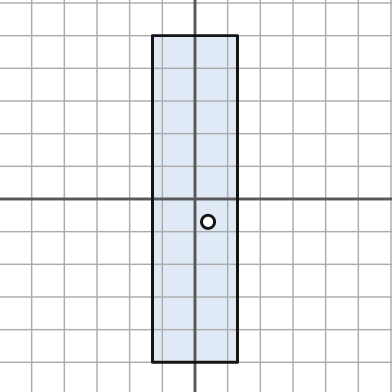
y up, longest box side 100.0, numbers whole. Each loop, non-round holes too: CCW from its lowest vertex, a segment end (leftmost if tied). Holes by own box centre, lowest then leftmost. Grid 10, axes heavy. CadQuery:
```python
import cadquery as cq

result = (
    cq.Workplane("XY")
    .moveTo(-13.0, -50.0)
    .lineTo(13.0, -50.0)
    .lineTo(13.0, 50.0)
    .lineTo(-13.0, 50.0)
    .close()
    .moveTo(4.0, -7.0)
    .circle(2.0)
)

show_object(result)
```